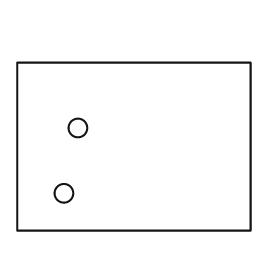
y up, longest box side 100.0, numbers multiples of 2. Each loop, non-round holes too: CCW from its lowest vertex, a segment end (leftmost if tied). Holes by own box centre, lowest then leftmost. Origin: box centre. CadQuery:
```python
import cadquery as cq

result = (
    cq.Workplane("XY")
    .moveTo(-50.0, -36.0)
    .lineTo(50.0, -36.0)
    .lineTo(50.0, 36.0)
    .lineTo(-50.0, 36.0)
    .close()
    .moveTo(-30.0, -20.0)
    .circle(4.0)
    .moveTo(-24.0, 8.0)
    .circle(4.0)
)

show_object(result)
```